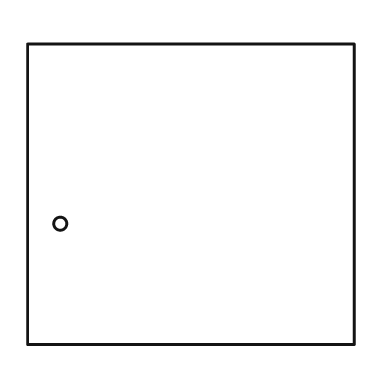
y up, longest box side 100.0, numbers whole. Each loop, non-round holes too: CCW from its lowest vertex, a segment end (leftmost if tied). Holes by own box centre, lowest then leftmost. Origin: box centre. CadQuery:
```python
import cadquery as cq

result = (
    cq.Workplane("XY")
    .moveTo(-50.0, -46.0)
    .lineTo(50.0, -46.0)
    .lineTo(50.0, 46.0)
    .lineTo(-50.0, 46.0)
    .close()
    .moveTo(-40.0, -9.0)
    .circle(2.0)
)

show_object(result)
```